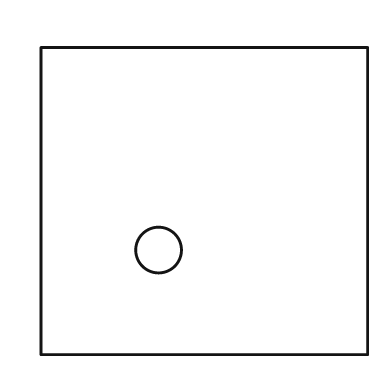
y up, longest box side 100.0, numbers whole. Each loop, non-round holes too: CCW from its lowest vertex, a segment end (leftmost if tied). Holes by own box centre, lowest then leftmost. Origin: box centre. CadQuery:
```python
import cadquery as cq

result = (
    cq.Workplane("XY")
    .moveTo(-50.0, -47.0)
    .lineTo(50.0, -47.0)
    .lineTo(50.0, 47.0)
    .lineTo(-50.0, 47.0)
    .close()
    .moveTo(-14.0, -15.0)
    .circle(7.0)
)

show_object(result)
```